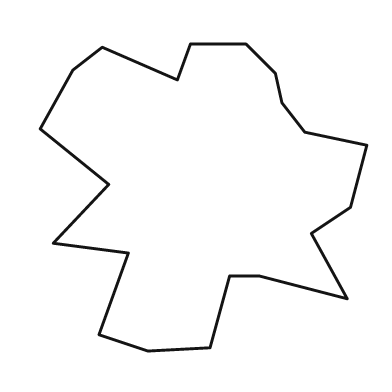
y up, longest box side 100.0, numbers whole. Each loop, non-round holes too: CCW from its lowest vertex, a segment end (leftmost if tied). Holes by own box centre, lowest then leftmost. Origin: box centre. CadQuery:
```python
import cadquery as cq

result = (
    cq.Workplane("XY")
    .moveTo(-17.0, -47.0)
    .lineTo(2.0, -46.0)
    .lineTo(8.0, -24.0)
    .lineTo(17.0, -24.0)
    .lineTo(44.0, -31.0)
    .lineTo(33.0, -11.0)
    .lineTo(45.0, -3.0)
    .lineTo(50.0, 16.0)
    .lineTo(31.0, 20.0)
    .lineTo(24.0, 29.0)
    .lineTo(22.0, 38.0)
    .lineTo(13.0, 47.0)
    .lineTo(-4.0, 47.0)
    .lineTo(-8.0, 36.0)
    .lineTo(-31.0, 46.0)
    .lineTo(-40.0, 39.0)
    .lineTo(-50.0, 21.0)
    .lineTo(-29.0, 4.0)
    .lineTo(-46.0, -14.0)
    .lineTo(-23.0, -17.0)
    .lineTo(-32.0, -42.0)
    .close()
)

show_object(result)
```